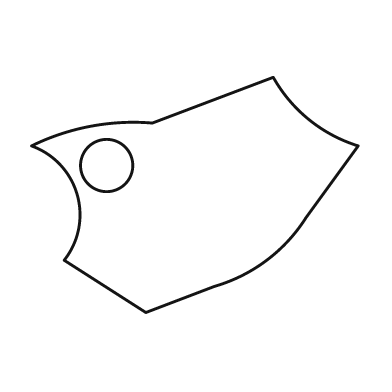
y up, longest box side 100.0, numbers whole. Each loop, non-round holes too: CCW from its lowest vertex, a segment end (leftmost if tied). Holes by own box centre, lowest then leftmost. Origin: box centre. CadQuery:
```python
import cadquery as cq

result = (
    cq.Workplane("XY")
    .moveTo(-15.0, -36.0)
    .lineTo(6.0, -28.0)
    .threePointArc((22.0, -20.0), (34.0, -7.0))
    .lineTo(50.0, 15.0)
    .threePointArc((35.0, 23.0), (24.0, 36.0))
    .lineTo(-13.0, 22.0)
    .threePointArc((-32.0, 21.0), (-50.0, 15.0))
    .threePointArc((-36.0, 0.0), (-40.0, -20.0))
    .close()
    .moveTo(-27.0, 9.0)
    .circle(8.0)
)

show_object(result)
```